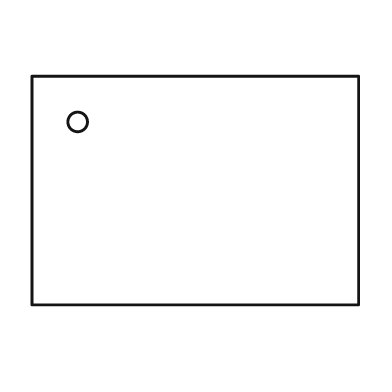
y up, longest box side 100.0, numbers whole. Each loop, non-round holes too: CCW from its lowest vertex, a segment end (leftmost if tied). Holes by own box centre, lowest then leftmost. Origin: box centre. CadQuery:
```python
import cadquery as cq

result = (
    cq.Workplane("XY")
    .moveTo(-50.0, -35.0)
    .lineTo(50.0, -35.0)
    .lineTo(50.0, 35.0)
    .lineTo(-50.0, 35.0)
    .close()
    .moveTo(-36.0, 21.0)
    .circle(3.0)
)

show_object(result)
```